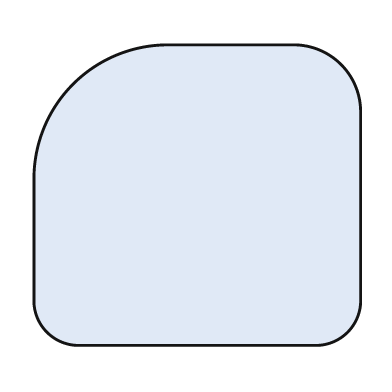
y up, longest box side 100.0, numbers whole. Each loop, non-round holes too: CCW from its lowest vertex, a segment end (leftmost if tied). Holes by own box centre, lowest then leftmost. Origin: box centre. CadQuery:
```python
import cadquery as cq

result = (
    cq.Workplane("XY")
    .moveTo(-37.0, -46.0)
    .lineTo(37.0, -46.0)
    .threePointArc((46.0, -42.0), (50.0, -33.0))
    .lineTo(50.0, 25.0)
    .threePointArc((44.0, 40.0), (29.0, 46.0))
    .lineTo(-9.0, 46.0)
    .threePointArc((-38.0, 34.0), (-50.0, 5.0))
    .lineTo(-50.0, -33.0)
    .threePointArc((-46.0, -42.0), (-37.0, -46.0))
    .close()
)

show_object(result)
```